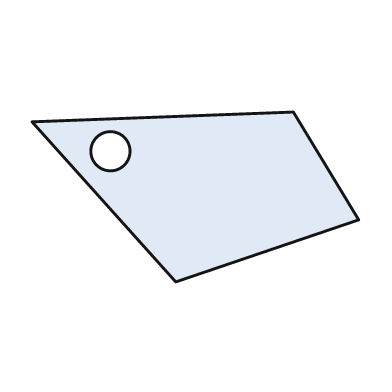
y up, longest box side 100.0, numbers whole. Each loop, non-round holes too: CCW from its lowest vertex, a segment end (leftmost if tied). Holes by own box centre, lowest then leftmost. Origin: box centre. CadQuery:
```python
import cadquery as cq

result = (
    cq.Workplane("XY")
    .moveTo(-6.0, -26.0)
    .lineTo(50.0, -7.0)
    .lineTo(30.0, 26.0)
    .lineTo(-50.0, 23.0)
    .close()
    .moveTo(-26.0, 14.0)
    .circle(6.0)
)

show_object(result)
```